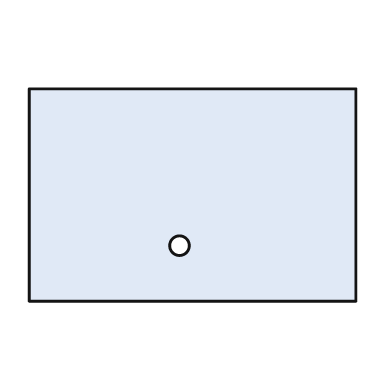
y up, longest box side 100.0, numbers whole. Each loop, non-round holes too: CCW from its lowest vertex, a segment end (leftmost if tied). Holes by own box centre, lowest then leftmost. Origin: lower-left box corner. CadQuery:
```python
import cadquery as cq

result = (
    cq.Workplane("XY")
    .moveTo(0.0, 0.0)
    .lineTo(100.0, 0.0)
    .lineTo(100.0, 65.0)
    .lineTo(0.0, 65.0)
    .close()
    .moveTo(46.0, 17.0)
    .circle(3.0)
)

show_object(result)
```